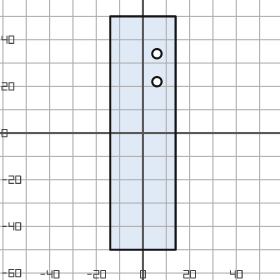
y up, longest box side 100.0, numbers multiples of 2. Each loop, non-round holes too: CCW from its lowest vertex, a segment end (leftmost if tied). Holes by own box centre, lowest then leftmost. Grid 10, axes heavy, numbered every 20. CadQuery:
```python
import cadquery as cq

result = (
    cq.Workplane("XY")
    .moveTo(-14.0, -50.0)
    .lineTo(14.0, -50.0)
    .lineTo(14.0, 50.0)
    .lineTo(-14.0, 50.0)
    .close()
    .moveTo(6.0, 22.0)
    .circle(2.0)
    .moveTo(6.0, 34.0)
    .circle(2.0)
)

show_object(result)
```